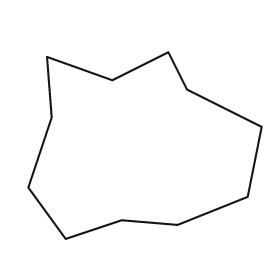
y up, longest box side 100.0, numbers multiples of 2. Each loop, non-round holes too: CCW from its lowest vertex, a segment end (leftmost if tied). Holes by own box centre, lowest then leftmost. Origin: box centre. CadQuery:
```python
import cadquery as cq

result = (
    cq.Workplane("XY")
    .moveTo(-34.0, -40.0)
    .lineTo(-10.0, -32.0)
    .lineTo(14.0, -34.0)
    .lineTo(44.0, -22.0)
    .lineTo(50.0, 8.0)
    .lineTo(18.0, 24.0)
    .lineTo(10.0, 40.0)
    .lineTo(-14.0, 28.0)
    .lineTo(-42.0, 38.0)
    .lineTo(-40.0, 12.0)
    .lineTo(-50.0, -18.0)
    .close()
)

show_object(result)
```